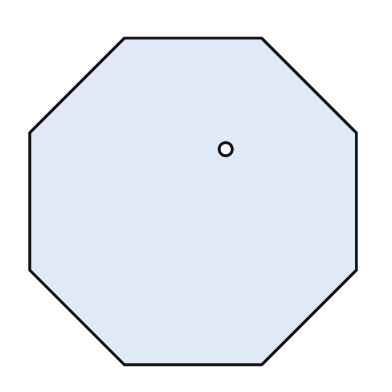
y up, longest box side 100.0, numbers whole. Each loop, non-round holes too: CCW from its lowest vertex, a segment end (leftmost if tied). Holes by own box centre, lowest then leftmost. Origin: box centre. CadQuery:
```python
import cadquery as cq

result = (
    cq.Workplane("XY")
    .moveTo(-21.0, -50.0)
    .lineTo(21.0, -50.0)
    .lineTo(50.0, -21.0)
    .lineTo(50.0, 21.0)
    .lineTo(21.0, 50.0)
    .lineTo(-21.0, 50.0)
    .lineTo(-50.0, 21.0)
    .lineTo(-50.0, -21.0)
    .close()
    .moveTo(10.0, 16.0)
    .circle(2.0)
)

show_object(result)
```